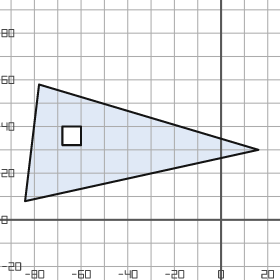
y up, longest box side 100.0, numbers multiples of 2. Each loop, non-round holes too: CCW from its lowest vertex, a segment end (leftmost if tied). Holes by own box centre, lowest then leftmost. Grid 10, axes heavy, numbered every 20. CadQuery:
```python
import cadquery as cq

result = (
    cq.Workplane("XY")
    .moveTo(-84.0, 8.0)
    .lineTo(16.0, 30.0)
    .lineTo(-78.0, 58.0)
    .close()
    .moveTo(-68.0, 32.0)
    .lineTo(-60.0, 32.0)
    .lineTo(-60.0, 40.0)
    .lineTo(-68.0, 40.0)
    .close()
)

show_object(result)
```